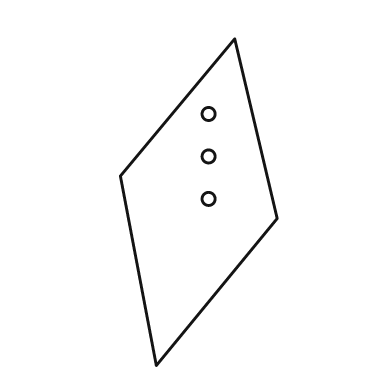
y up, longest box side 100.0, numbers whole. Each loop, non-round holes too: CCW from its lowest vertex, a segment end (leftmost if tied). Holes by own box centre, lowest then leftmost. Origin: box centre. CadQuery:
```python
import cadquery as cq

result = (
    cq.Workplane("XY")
    .moveTo(-13.0, -50.0)
    .lineTo(24.0, -5.0)
    .lineTo(11.0, 50.0)
    .lineTo(-24.0, 8.0)
    .close()
    .moveTo(3.0, 1.0)
    .circle(2.0)
    .moveTo(3.0, 14.0)
    .circle(2.0)
    .moveTo(3.0, 27.0)
    .circle(2.0)
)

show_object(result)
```